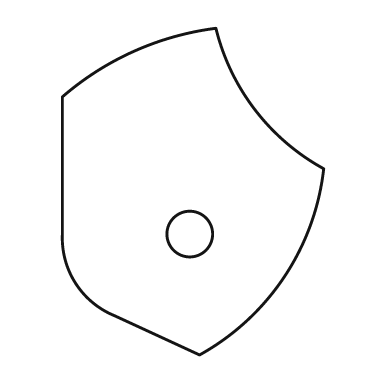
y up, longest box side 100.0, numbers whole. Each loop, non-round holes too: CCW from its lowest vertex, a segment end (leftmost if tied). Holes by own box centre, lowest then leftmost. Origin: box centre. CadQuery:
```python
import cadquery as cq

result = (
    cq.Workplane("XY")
    .moveTo(2.0, -50.0)
    .threePointArc((28.0, -26.0), (40.0, 7.0))
    .threePointArc((19.0, 25.0), (7.0, 50.0))
    .threePointArc((-18.0, 43.0), (-40.0, 29.0))
    .lineTo(-40.0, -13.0)
    .threePointArc((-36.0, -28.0), (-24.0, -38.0))
    .close()
    .moveTo(-1.0, -13.0)
    .circle(7.0)
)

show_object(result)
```